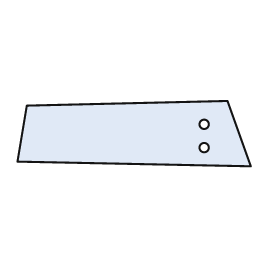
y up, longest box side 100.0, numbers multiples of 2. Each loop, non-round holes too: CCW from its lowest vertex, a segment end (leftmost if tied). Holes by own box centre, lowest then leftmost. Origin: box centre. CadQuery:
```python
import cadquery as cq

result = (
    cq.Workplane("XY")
    .moveTo(50.0, -14.0)
    .lineTo(40.0, 14.0)
    .lineTo(-46.0, 12.0)
    .lineTo(-50.0, -12.0)
    .close()
    .moveTo(30.0, -6.0)
    .circle(2.0)
    .moveTo(30.0, 4.0)
    .circle(2.0)
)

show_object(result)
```